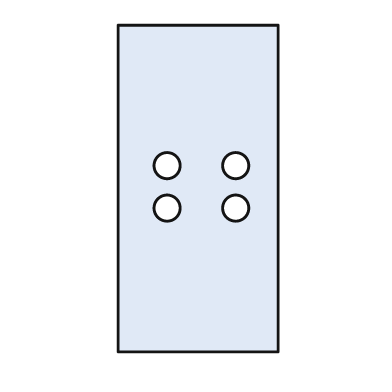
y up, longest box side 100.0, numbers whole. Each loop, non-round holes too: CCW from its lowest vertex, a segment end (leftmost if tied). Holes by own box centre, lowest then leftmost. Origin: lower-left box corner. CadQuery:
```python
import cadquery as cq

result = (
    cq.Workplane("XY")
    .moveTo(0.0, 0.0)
    .lineTo(49.0, 0.0)
    .lineTo(49.0, 100.0)
    .lineTo(0.0, 100.0)
    .close()
    .moveTo(15.0, 44.0)
    .circle(4.0)
    .moveTo(36.0, 44.0)
    .circle(4.0)
    .moveTo(15.0, 57.0)
    .circle(4.0)
    .moveTo(36.0, 57.0)
    .circle(4.0)
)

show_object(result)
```